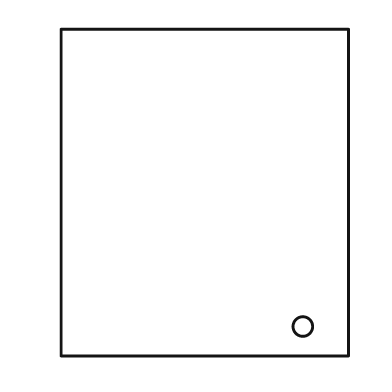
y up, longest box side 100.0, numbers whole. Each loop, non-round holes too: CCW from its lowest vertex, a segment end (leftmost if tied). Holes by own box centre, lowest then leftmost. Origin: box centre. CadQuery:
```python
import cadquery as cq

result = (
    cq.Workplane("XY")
    .moveTo(-44.0, -50.0)
    .lineTo(44.0, -50.0)
    .lineTo(44.0, 50.0)
    .lineTo(-44.0, 50.0)
    .close()
    .moveTo(30.0, -41.0)
    .circle(3.0)
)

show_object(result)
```